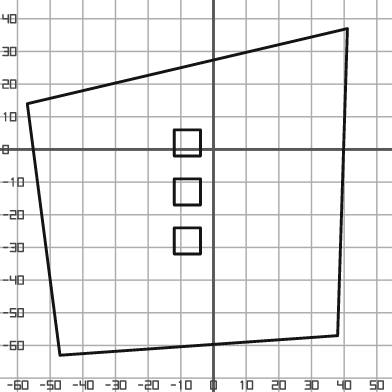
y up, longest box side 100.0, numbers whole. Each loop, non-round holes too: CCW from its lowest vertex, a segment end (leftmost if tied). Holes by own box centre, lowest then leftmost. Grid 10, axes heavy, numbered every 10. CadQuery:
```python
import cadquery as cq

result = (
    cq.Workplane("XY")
    .moveTo(-47.0, -63.0)
    .lineTo(38.0, -57.0)
    .lineTo(41.0, 37.0)
    .lineTo(-57.0, 14.0)
    .close()
    .moveTo(-12.0, -32.0)
    .lineTo(-4.0, -32.0)
    .lineTo(-4.0, -24.0)
    .lineTo(-12.0, -24.0)
    .close()
    .moveTo(-12.0, -17.0)
    .lineTo(-4.0, -17.0)
    .lineTo(-4.0, -9.0)
    .lineTo(-12.0, -9.0)
    .close()
    .moveTo(-12.0, -2.0)
    .lineTo(-4.0, -2.0)
    .lineTo(-4.0, 6.0)
    .lineTo(-12.0, 6.0)
    .close()
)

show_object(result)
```